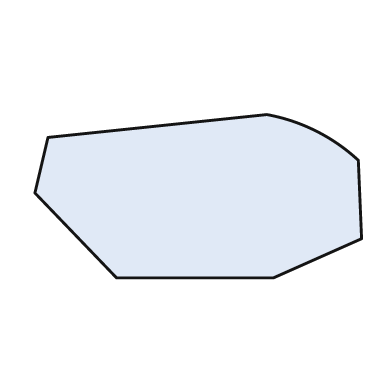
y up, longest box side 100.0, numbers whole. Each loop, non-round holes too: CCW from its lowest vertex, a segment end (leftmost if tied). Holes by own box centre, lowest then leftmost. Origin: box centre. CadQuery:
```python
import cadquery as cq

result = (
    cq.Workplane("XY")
    .moveTo(-25.0, -25.0)
    .lineTo(23.0, -25.0)
    .lineTo(50.0, -13.0)
    .lineTo(49.0, 11.0)
    .threePointArc((36.0, 20.0), (21.0, 25.0))
    .lineTo(-46.0, 18.0)
    .lineTo(-50.0, 1.0)
    .close()
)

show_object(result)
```